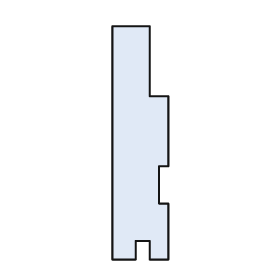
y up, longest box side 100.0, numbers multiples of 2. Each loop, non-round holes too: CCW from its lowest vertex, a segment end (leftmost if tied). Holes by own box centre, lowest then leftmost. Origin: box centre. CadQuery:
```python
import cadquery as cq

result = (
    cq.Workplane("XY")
    .moveTo(-12.0, -50.0)
    .lineTo(-2.0, -50.0)
    .lineTo(-2.0, -42.0)
    .lineTo(4.0, -42.0)
    .lineTo(4.0, -50.0)
    .lineTo(12.0, -50.0)
    .lineTo(12.0, -26.0)
    .lineTo(8.0, -26.0)
    .lineTo(8.0, -10.0)
    .lineTo(12.0, -10.0)
    .lineTo(12.0, 20.0)
    .lineTo(4.0, 20.0)
    .lineTo(4.0, 50.0)
    .lineTo(-12.0, 50.0)
    .close()
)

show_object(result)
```